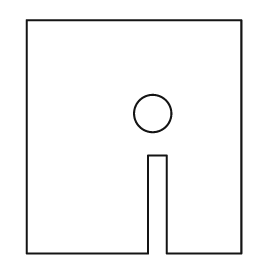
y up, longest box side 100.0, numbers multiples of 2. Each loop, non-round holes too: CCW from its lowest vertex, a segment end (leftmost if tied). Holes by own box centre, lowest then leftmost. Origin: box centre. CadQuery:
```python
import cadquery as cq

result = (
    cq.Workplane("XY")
    .moveTo(-46.0, -50.0)
    .lineTo(6.0, -50.0)
    .lineTo(6.0, -8.0)
    .lineTo(14.0, -8.0)
    .lineTo(14.0, -50.0)
    .lineTo(46.0, -50.0)
    .lineTo(46.0, 50.0)
    .lineTo(-46.0, 50.0)
    .close()
    .moveTo(8.0, 10.0)
    .circle(8.0)
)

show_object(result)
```